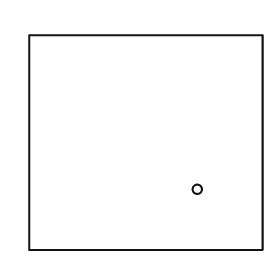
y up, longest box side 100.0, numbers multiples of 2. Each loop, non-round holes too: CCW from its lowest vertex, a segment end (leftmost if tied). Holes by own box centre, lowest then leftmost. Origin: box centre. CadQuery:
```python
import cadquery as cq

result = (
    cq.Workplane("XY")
    .moveTo(-50.0, -46.0)
    .lineTo(50.0, -46.0)
    .lineTo(50.0, 46.0)
    .lineTo(-50.0, 46.0)
    .close()
    .moveTo(22.0, -20.0)
    .circle(2.0)
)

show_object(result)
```